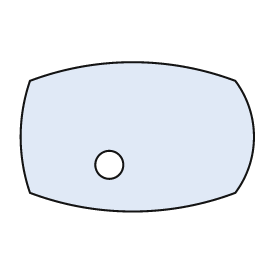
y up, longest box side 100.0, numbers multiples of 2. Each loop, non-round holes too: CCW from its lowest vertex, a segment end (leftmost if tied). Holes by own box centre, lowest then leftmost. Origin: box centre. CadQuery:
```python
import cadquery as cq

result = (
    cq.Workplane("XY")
    .moveTo(-46.0, -24.0)
    .threePointArc((-2.0, -32.0), (42.0, -24.0))
    .threePointArc((50.0, 0.0), (42.0, 24.0))
    .threePointArc((-2.0, 32.0), (-46.0, 24.0))
    .threePointArc((-50.0, 0.0), (-46.0, -24.0))
    .close()
    .moveTo(-12.0, -12.0)
    .circle(6.0)
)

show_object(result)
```